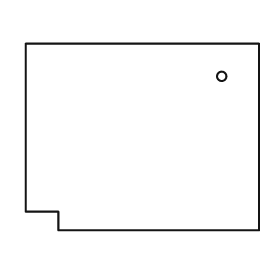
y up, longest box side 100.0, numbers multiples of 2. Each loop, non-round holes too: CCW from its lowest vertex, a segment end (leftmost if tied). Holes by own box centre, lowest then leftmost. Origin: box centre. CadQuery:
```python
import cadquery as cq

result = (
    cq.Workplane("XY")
    .moveTo(-36.0, -40.0)
    .lineTo(50.0, -40.0)
    .lineTo(50.0, 40.0)
    .lineTo(-50.0, 40.0)
    .lineTo(-50.0, -32.0)
    .lineTo(-36.0, -32.0)
    .close()
    .moveTo(34.0, 26.0)
    .circle(2.0)
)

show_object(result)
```